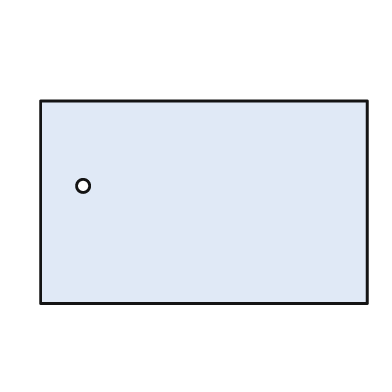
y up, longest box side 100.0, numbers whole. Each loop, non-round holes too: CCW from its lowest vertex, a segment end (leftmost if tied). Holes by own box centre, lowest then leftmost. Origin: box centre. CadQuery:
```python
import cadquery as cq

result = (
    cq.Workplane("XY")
    .moveTo(-50.0, -31.0)
    .lineTo(50.0, -31.0)
    .lineTo(50.0, 31.0)
    .lineTo(-50.0, 31.0)
    .close()
    .moveTo(-37.0, 5.0)
    .circle(2.0)
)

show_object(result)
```